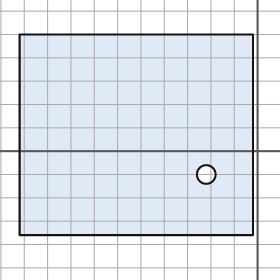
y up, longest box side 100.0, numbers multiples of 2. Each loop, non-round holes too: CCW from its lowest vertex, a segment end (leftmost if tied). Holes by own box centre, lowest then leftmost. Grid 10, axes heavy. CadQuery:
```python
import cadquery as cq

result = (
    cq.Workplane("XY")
    .moveTo(-102.0, -36.0)
    .lineTo(-2.0, -36.0)
    .lineTo(-2.0, 50.0)
    .lineTo(-102.0, 50.0)
    .close()
    .moveTo(-22.0, -10.0)
    .circle(4.0)
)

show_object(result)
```